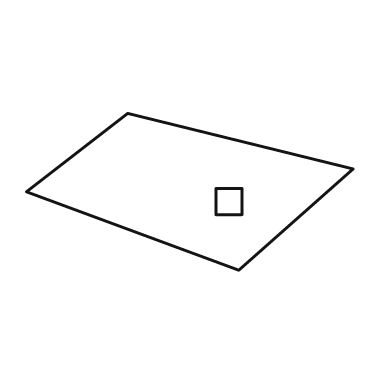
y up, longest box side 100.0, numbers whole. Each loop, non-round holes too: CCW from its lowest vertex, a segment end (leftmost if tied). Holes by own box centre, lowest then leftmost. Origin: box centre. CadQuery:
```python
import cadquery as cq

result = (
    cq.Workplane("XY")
    .moveTo(15.0, -24.0)
    .lineTo(50.0, 7.0)
    .lineTo(-19.0, 24.0)
    .lineTo(-50.0, 0.0)
    .close()
    .moveTo(8.0, -7.0)
    .lineTo(16.0, -7.0)
    .lineTo(16.0, 1.0)
    .lineTo(8.0, 1.0)
    .close()
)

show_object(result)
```